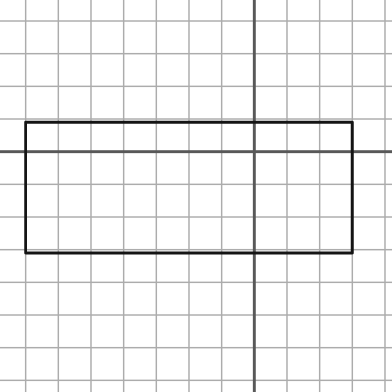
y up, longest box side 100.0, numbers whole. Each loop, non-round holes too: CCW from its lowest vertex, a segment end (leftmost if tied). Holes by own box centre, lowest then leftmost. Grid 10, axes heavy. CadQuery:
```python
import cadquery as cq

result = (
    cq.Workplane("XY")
    .moveTo(-70.0, -31.0)
    .lineTo(30.0, -31.0)
    .lineTo(30.0, 9.0)
    .lineTo(-70.0, 9.0)
    .close()
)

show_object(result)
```